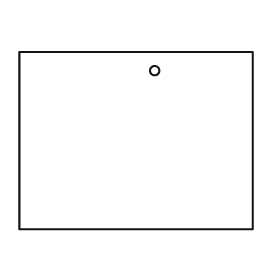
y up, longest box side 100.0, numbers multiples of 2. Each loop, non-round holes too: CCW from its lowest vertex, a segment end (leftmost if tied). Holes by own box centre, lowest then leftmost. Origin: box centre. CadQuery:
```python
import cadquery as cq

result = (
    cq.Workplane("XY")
    .moveTo(-50.0, -38.0)
    .lineTo(50.0, -38.0)
    .lineTo(50.0, 38.0)
    .lineTo(-50.0, 38.0)
    .close()
    .moveTo(8.0, 30.0)
    .circle(2.0)
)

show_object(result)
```